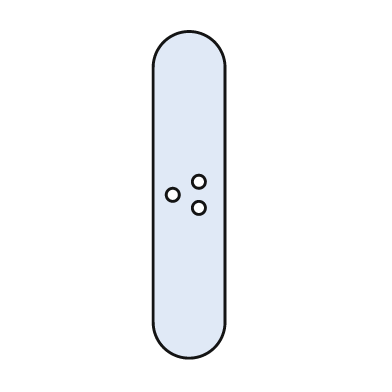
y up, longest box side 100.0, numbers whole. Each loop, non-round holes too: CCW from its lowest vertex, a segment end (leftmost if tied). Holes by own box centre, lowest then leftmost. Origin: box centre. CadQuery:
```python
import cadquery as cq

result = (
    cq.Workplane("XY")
    .moveTo(-11.0, -39.0)
    .threePointArc((0.0, -50.0), (11.0, -39.0))
    .lineTo(11.0, 39.0)
    .threePointArc((0.0, 50.0), (-11.0, 39.0))
    .close()
    .moveTo(3.0, -4.0)
    .circle(2.0)
    .moveTo(-5.0, 0.0)
    .circle(2.0)
    .moveTo(3.0, 4.0)
    .circle(2.0)
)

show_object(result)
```